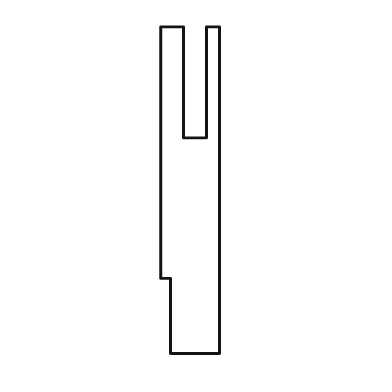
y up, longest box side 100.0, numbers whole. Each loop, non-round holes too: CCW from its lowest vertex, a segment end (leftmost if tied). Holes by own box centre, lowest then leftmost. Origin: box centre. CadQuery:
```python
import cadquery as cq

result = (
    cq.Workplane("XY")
    .moveTo(-6.0, -50.0)
    .lineTo(9.0, -50.0)
    .lineTo(9.0, 50.0)
    .lineTo(5.0, 50.0)
    .lineTo(5.0, 16.0)
    .lineTo(-2.0, 16.0)
    .lineTo(-2.0, 50.0)
    .lineTo(-9.0, 50.0)
    .lineTo(-9.0, -27.0)
    .lineTo(-6.0, -27.0)
    .close()
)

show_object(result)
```